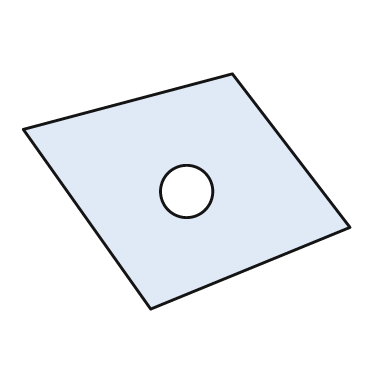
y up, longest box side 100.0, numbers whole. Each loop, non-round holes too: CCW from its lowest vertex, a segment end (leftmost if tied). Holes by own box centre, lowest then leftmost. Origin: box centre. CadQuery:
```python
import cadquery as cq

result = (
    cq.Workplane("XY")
    .moveTo(-11.0, -36.0)
    .lineTo(50.0, -11.0)
    .lineTo(14.0, 36.0)
    .lineTo(-50.0, 19.0)
    .close()
    .moveTo(0.0, 0.0)
    .circle(8.0)
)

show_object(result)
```